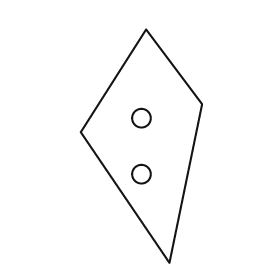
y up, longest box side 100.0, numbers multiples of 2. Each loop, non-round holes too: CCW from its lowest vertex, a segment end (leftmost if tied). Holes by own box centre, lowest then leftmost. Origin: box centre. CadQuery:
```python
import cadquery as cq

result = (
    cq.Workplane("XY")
    .moveTo(12.0, -50.0)
    .lineTo(26.0, 18.0)
    .lineTo(2.0, 50.0)
    .lineTo(-26.0, 6.0)
    .close()
    .moveTo(0.0, -12.0)
    .circle(4.0)
    .moveTo(0.0, 12.0)
    .circle(4.0)
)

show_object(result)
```